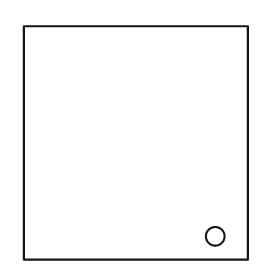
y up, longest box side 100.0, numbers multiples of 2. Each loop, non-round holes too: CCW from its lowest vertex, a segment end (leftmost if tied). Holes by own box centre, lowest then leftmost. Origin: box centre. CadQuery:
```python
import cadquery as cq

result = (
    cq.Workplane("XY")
    .moveTo(-48.0, -50.0)
    .lineTo(48.0, -50.0)
    .lineTo(48.0, 50.0)
    .lineTo(-48.0, 50.0)
    .close()
    .moveTo(34.0, -40.0)
    .circle(4.0)
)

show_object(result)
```